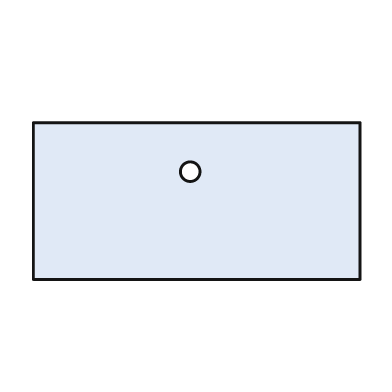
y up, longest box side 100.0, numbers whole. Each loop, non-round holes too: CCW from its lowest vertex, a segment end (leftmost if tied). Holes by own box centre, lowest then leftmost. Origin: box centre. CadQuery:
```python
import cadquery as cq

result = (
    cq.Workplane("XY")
    .moveTo(-50.0, -24.0)
    .lineTo(50.0, -24.0)
    .lineTo(50.0, 24.0)
    .lineTo(-50.0, 24.0)
    .close()
    .moveTo(-2.0, 9.0)
    .circle(3.0)
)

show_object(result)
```